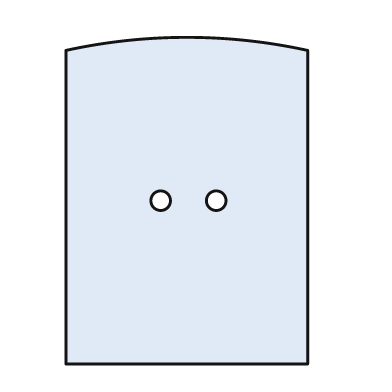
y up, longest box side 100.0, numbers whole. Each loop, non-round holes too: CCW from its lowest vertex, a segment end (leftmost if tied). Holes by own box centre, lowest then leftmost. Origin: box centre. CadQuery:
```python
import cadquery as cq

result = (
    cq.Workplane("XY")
    .moveTo(-37.0, -50.0)
    .lineTo(37.0, -50.0)
    .lineTo(37.0, 46.0)
    .threePointArc((0.0, 50.0), (-37.0, 46.0))
    .close()
    .moveTo(-8.0, 0.0)
    .circle(3.0)
    .moveTo(9.0, 0.0)
    .circle(3.0)
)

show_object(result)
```